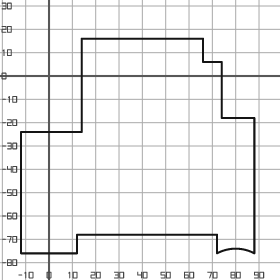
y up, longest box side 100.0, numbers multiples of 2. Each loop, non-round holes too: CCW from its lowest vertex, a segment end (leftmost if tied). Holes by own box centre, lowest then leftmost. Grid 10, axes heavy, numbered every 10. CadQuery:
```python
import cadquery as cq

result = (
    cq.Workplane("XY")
    .moveTo(-12.0, -76.0)
    .lineTo(12.0, -76.0)
    .lineTo(12.0, -68.0)
    .lineTo(72.0, -68.0)
    .lineTo(72.0, -76.0)
    .threePointArc((80.0, -74.0), (88.0, -76.0))
    .lineTo(88.0, -18.0)
    .lineTo(74.0, -18.0)
    .lineTo(74.0, 6.0)
    .lineTo(66.0, 6.0)
    .lineTo(66.0, 16.0)
    .lineTo(14.0, 16.0)
    .lineTo(14.0, -24.0)
    .lineTo(-12.0, -24.0)
    .close()
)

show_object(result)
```